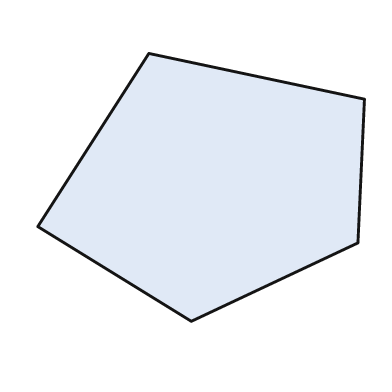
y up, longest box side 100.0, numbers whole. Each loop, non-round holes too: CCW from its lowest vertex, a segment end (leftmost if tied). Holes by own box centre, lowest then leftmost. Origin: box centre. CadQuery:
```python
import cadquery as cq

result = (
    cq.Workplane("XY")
    .moveTo(-3.0, -41.0)
    .lineTo(48.0, -17.0)
    .lineTo(50.0, 27.0)
    .lineTo(-16.0, 41.0)
    .lineTo(-50.0, -12.0)
    .close()
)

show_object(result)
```